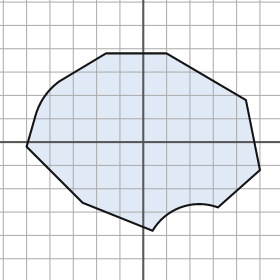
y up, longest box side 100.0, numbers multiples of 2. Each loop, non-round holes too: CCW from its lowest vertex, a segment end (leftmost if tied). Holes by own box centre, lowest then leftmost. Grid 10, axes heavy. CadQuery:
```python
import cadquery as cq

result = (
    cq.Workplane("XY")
    .moveTo(4.0, -38.0)
    .threePointArc((16.0, -28.0), (32.0, -28.0))
    .lineTo(50.0, -12.0)
    .lineTo(44.0, 18.0)
    .lineTo(10.0, 38.0)
    .lineTo(-16.0, 38.0)
    .lineTo(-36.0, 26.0)
    .threePointArc((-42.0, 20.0), (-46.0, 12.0))
    .lineTo(-50.0, -2.0)
    .lineTo(-26.0, -26.0)
    .close()
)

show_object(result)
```